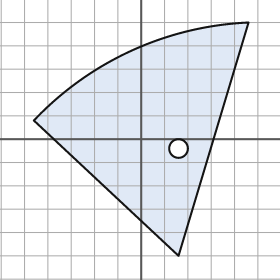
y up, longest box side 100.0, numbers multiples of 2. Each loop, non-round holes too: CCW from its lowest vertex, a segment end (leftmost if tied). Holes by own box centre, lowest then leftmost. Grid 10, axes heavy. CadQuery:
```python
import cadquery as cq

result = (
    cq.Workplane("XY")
    .moveTo(16.0, -50.0)
    .lineTo(46.0, 50.0)
    .threePointArc((-4.0, 38.0), (-46.0, 8.0))
    .close()
    .moveTo(16.0, -4.0)
    .circle(4.0)
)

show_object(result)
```